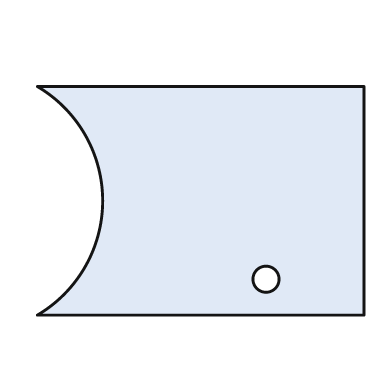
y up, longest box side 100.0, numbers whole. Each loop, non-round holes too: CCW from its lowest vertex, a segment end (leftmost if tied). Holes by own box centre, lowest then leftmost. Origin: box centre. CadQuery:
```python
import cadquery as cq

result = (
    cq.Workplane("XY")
    .moveTo(-50.0, -35.0)
    .lineTo(50.0, -35.0)
    .lineTo(50.0, 35.0)
    .lineTo(-50.0, 35.0)
    .threePointArc((-30.0, 0.0), (-50.0, -35.0))
    .close()
    .moveTo(20.0, -24.0)
    .circle(4.0)
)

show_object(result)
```